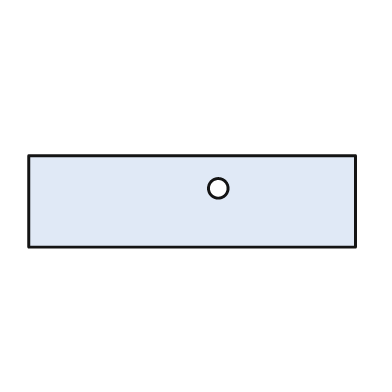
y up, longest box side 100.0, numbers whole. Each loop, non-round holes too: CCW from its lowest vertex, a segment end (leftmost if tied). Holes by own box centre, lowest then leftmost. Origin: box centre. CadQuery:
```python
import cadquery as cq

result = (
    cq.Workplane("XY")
    .moveTo(-50.0, -14.0)
    .lineTo(50.0, -14.0)
    .lineTo(50.0, 14.0)
    .lineTo(-50.0, 14.0)
    .close()
    .moveTo(8.0, 4.0)
    .circle(3.0)
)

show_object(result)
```